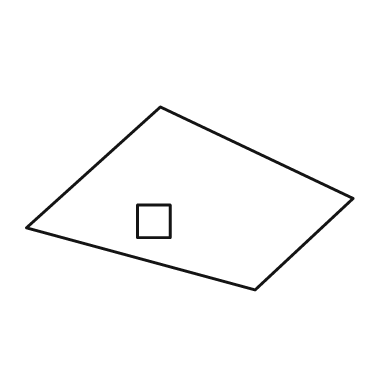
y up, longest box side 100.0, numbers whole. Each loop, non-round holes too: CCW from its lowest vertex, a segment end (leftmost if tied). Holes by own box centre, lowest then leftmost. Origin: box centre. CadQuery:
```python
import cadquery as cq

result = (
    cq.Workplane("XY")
    .moveTo(20.0, -28.0)
    .lineTo(50.0, 0.0)
    .lineTo(-9.0, 28.0)
    .lineTo(-50.0, -9.0)
    .close()
    .moveTo(-16.0, -12.0)
    .lineTo(-6.0, -12.0)
    .lineTo(-6.0, -2.0)
    .lineTo(-16.0, -2.0)
    .close()
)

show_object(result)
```